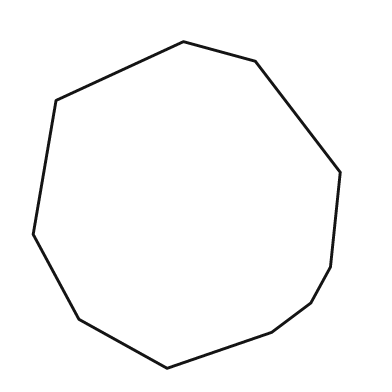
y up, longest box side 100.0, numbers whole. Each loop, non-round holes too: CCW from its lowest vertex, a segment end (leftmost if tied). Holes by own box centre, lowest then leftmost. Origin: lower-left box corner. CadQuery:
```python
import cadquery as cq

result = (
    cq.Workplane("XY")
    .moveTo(41.0, 0.0)
    .lineTo(73.0, 11.0)
    .lineTo(85.0, 20.0)
    .lineTo(91.0, 31.0)
    .lineTo(94.0, 60.0)
    .lineTo(68.0, 94.0)
    .lineTo(46.0, 100.0)
    .lineTo(7.0, 82.0)
    .lineTo(0.0, 41.0)
    .lineTo(14.0, 15.0)
    .close()
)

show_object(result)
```